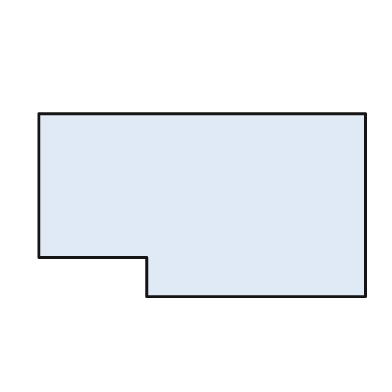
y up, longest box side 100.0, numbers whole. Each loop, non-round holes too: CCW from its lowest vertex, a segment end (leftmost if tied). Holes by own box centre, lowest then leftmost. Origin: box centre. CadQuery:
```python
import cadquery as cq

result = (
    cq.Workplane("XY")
    .moveTo(-17.0, -28.0)
    .lineTo(50.0, -28.0)
    .lineTo(50.0, 28.0)
    .lineTo(-50.0, 28.0)
    .lineTo(-50.0, -16.0)
    .lineTo(-17.0, -16.0)
    .close()
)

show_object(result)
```